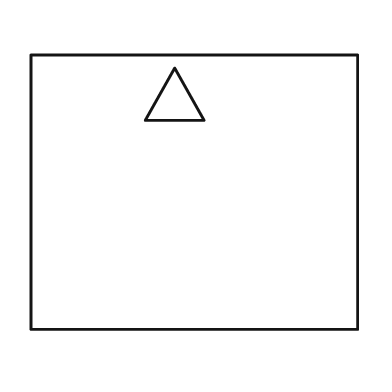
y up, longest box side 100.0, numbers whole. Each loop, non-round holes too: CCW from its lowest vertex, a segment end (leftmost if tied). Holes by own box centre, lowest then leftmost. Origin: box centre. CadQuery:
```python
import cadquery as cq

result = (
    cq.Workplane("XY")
    .moveTo(-50.0, -42.0)
    .lineTo(50.0, -42.0)
    .lineTo(50.0, 42.0)
    .lineTo(-50.0, 42.0)
    .close()
    .moveTo(-15.0, 22.0)
    .lineTo(3.0, 22.0)
    .lineTo(-6.0, 38.0)
    .close()
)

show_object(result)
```